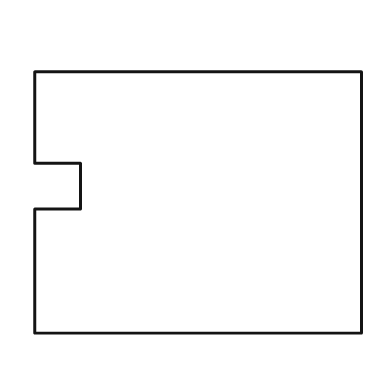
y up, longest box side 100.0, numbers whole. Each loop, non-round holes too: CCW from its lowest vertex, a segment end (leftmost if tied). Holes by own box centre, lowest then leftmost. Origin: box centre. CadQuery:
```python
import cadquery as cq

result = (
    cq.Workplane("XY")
    .moveTo(-50.0, -40.0)
    .lineTo(50.0, -40.0)
    .lineTo(50.0, 40.0)
    .lineTo(-50.0, 40.0)
    .lineTo(-50.0, 12.0)
    .lineTo(-36.0, 12.0)
    .lineTo(-36.0, -2.0)
    .lineTo(-50.0, -2.0)
    .close()
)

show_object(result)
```